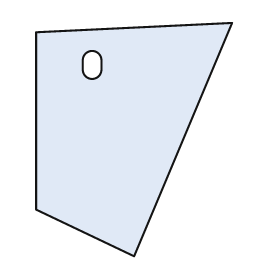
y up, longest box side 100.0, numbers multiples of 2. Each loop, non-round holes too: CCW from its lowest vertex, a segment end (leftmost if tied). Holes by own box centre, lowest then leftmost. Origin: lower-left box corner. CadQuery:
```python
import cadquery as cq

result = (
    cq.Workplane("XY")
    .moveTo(42.0, 0.0)
    .lineTo(84.0, 100.0)
    .lineTo(0.0, 96.0)
    .lineTo(0.0, 20.0)
    .close()
    .moveTo(20.0, 80.0)
    .threePointArc((24.0, 76.0), (28.0, 80.0))
    .lineTo(28.0, 84.0)
    .threePointArc((24.0, 88.0), (20.0, 84.0))
    .close()
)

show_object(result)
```